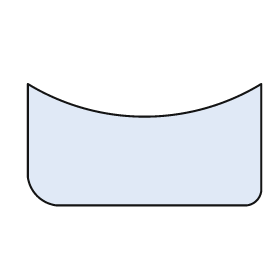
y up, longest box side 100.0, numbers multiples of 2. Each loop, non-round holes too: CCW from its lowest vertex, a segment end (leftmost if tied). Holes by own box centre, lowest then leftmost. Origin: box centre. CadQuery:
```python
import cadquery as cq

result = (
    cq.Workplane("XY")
    .moveTo(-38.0, -26.0)
    .lineTo(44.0, -26.0)
    .threePointArc((48.0, -24.0), (50.0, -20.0))
    .lineTo(50.0, 26.0)
    .threePointArc((0.0, 12.0), (-50.0, 26.0))
    .lineTo(-50.0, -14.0)
    .threePointArc((-46.0, -22.0), (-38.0, -26.0))
    .close()
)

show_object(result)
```